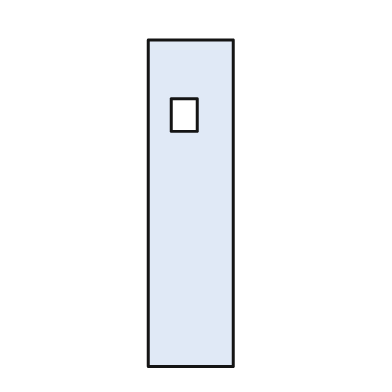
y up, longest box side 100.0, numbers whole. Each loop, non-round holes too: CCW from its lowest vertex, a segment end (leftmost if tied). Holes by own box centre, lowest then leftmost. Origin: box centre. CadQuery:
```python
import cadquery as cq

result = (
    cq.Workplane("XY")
    .moveTo(-13.0, -50.0)
    .lineTo(13.0, -50.0)
    .lineTo(13.0, 50.0)
    .lineTo(-13.0, 50.0)
    .close()
    .moveTo(-6.0, 22.0)
    .lineTo(2.0, 22.0)
    .lineTo(2.0, 32.0)
    .lineTo(-6.0, 32.0)
    .close()
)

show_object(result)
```